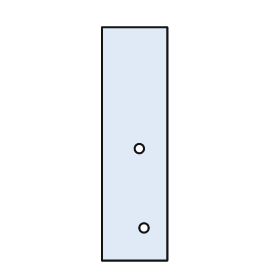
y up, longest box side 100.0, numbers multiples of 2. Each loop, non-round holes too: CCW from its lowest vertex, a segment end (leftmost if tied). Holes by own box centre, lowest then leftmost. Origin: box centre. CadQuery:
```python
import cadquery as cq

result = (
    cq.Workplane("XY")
    .moveTo(-14.0, -50.0)
    .lineTo(14.0, -50.0)
    .lineTo(14.0, 50.0)
    .lineTo(-14.0, 50.0)
    .close()
    .moveTo(4.0, -36.0)
    .circle(2.0)
    .moveTo(2.0, -2.0)
    .circle(2.0)
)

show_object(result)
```